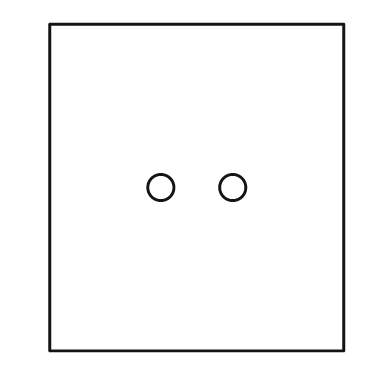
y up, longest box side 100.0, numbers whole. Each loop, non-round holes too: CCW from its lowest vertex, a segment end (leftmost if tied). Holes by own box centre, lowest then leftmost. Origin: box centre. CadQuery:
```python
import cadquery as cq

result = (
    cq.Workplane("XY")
    .moveTo(-45.0, -50.0)
    .lineTo(45.0, -50.0)
    .lineTo(45.0, 50.0)
    .lineTo(-45.0, 50.0)
    .close()
    .moveTo(-11.0, 0.0)
    .circle(4.0)
    .moveTo(11.0, 0.0)
    .circle(4.0)
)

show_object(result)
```